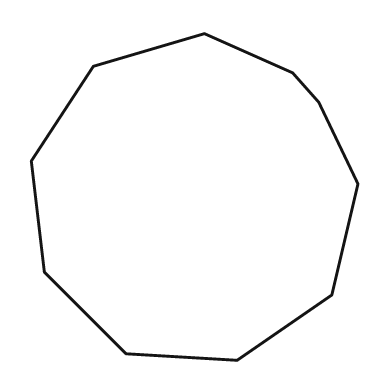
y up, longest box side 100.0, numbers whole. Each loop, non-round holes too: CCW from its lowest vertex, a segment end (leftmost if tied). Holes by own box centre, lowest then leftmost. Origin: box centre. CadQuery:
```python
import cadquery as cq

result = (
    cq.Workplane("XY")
    .moveTo(13.0, -50.0)
    .lineTo(42.0, -30.0)
    .lineTo(50.0, 4.0)
    .lineTo(38.0, 29.0)
    .lineTo(30.0, 38.0)
    .lineTo(3.0, 50.0)
    .lineTo(-31.0, 40.0)
    .lineTo(-50.0, 11.0)
    .lineTo(-46.0, -23.0)
    .lineTo(-21.0, -48.0)
    .close()
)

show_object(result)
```